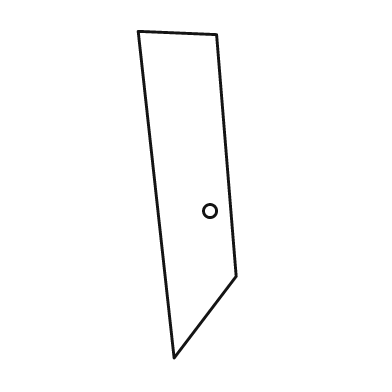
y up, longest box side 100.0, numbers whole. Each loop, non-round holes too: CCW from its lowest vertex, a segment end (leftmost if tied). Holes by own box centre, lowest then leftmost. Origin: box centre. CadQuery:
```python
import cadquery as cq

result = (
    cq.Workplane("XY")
    .moveTo(-4.0, -50.0)
    .lineTo(15.0, -25.0)
    .lineTo(9.0, 49.0)
    .lineTo(-15.0, 50.0)
    .close()
    .moveTo(7.0, -5.0)
    .circle(2.0)
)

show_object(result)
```